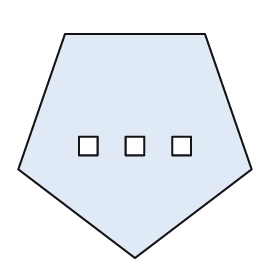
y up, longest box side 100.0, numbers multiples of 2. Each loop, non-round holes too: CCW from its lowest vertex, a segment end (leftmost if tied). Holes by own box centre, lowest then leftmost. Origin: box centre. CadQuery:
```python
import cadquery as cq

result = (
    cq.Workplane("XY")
    .moveTo(0.0, -48.0)
    .lineTo(50.0, -10.0)
    .lineTo(30.0, 48.0)
    .lineTo(-30.0, 48.0)
    .lineTo(-50.0, -10.0)
    .close()
    .moveTo(-24.0, -4.0)
    .lineTo(-16.0, -4.0)
    .lineTo(-16.0, 4.0)
    .lineTo(-24.0, 4.0)
    .close()
    .moveTo(-4.0, -4.0)
    .lineTo(4.0, -4.0)
    .lineTo(4.0, 4.0)
    .lineTo(-4.0, 4.0)
    .close()
    .moveTo(16.0, -4.0)
    .lineTo(24.0, -4.0)
    .lineTo(24.0, 4.0)
    .lineTo(16.0, 4.0)
    .close()
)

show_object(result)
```